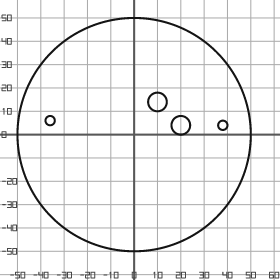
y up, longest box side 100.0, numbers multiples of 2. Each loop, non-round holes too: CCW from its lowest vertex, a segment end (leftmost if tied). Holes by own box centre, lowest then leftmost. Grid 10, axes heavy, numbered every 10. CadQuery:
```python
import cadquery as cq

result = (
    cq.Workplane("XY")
    .moveTo(0.0, 0.0)
    .circle(50.0)
    .moveTo(20.0, 4.0)
    .circle(4.0)
    .moveTo(38.0, 4.0)
    .circle(2.0)
    .moveTo(-36.0, 6.0)
    .circle(2.0)
    .moveTo(10.0, 14.0)
    .circle(4.0)
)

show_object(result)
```